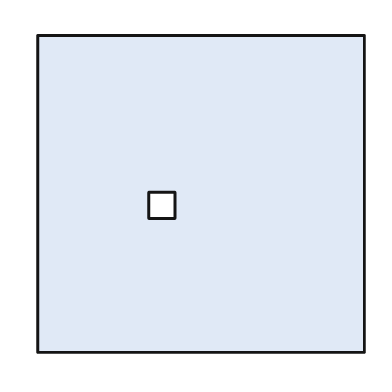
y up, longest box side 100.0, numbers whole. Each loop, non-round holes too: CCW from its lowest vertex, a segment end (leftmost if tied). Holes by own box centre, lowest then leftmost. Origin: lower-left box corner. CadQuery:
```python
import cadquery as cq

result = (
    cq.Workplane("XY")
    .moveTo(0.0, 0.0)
    .lineTo(100.0, 0.0)
    .lineTo(100.0, 97.0)
    .lineTo(0.0, 97.0)
    .close()
    .moveTo(34.0, 41.0)
    .lineTo(42.0, 41.0)
    .lineTo(42.0, 49.0)
    .lineTo(34.0, 49.0)
    .close()
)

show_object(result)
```